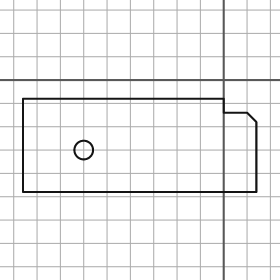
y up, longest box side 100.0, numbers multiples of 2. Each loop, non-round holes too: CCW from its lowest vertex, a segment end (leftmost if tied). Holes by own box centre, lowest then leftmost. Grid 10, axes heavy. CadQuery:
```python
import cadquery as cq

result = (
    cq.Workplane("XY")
    .moveTo(-86.0, -48.0)
    .lineTo(14.0, -48.0)
    .lineTo(14.0, -18.0)
    .lineTo(10.0, -14.0)
    .lineTo(0.0, -14.0)
    .lineTo(0.0, -8.0)
    .lineTo(-86.0, -8.0)
    .close()
    .moveTo(-60.0, -30.0)
    .circle(4.0)
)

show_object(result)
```